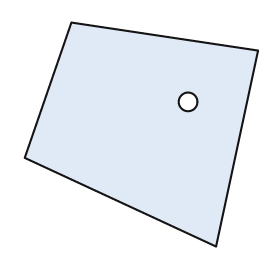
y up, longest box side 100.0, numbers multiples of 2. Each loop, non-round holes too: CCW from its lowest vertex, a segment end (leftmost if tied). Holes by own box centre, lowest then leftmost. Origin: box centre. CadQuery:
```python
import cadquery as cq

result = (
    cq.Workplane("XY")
    .moveTo(32.0, -48.0)
    .lineTo(50.0, 36.0)
    .lineTo(-30.0, 48.0)
    .lineTo(-50.0, -10.0)
    .close()
    .moveTo(20.0, 14.0)
    .circle(4.0)
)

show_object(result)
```